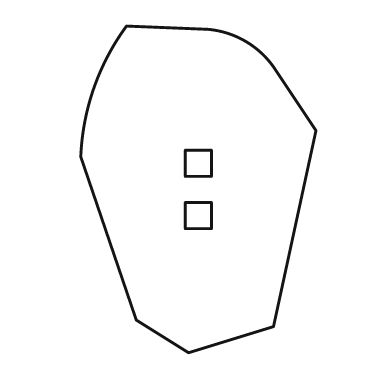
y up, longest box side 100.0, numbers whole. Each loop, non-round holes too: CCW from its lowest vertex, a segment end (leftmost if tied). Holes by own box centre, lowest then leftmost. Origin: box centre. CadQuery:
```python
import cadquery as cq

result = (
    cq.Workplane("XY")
    .moveTo(-3.0, -50.0)
    .lineTo(23.0, -42.0)
    .lineTo(36.0, 18.0)
    .lineTo(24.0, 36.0)
    .threePointArc((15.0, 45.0), (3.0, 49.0))
    .lineTo(-22.0, 50.0)
    .threePointArc((-32.0, 31.0), (-36.0, 10.0))
    .lineTo(-19.0, -40.0)
    .close()
    .moveTo(-4.0, -12.0)
    .lineTo(4.0, -12.0)
    .lineTo(4.0, -4.0)
    .lineTo(-4.0, -4.0)
    .close()
    .moveTo(-4.0, 4.0)
    .lineTo(4.0, 4.0)
    .lineTo(4.0, 12.0)
    .lineTo(-4.0, 12.0)
    .close()
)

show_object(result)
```